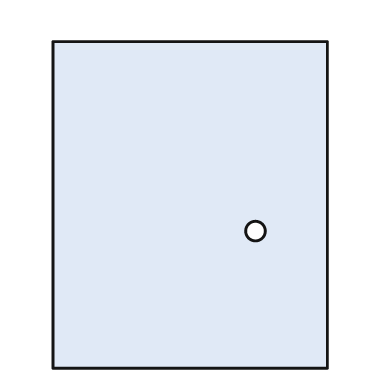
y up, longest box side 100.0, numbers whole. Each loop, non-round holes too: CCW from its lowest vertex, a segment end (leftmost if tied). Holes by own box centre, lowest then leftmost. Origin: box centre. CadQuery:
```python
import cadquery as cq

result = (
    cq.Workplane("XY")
    .moveTo(-42.0, -50.0)
    .lineTo(42.0, -50.0)
    .lineTo(42.0, 50.0)
    .lineTo(-42.0, 50.0)
    .close()
    .moveTo(20.0, -8.0)
    .circle(3.0)
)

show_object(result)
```